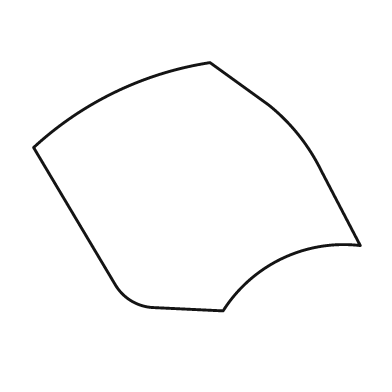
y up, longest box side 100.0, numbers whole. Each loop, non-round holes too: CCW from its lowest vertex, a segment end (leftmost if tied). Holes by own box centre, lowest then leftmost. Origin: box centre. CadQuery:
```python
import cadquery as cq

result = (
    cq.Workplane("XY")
    .moveTo(8.0, -38.0)
    .threePointArc((26.0, -22.0), (50.0, -18.0))
    .lineTo(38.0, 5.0)
    .threePointArc((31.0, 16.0), (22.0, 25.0))
    .lineTo(4.0, 38.0)
    .threePointArc((-25.0, 29.0), (-50.0, 12.0))
    .lineTo(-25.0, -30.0)
    .threePointArc((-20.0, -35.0), (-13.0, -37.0))
    .close()
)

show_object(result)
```